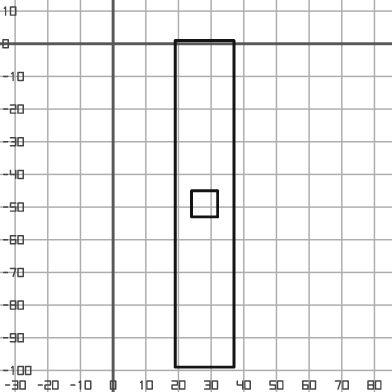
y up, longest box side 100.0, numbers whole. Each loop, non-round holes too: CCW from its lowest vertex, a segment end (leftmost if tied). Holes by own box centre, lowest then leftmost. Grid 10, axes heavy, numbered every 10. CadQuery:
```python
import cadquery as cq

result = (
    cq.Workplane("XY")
    .moveTo(19.0, -99.0)
    .lineTo(37.0, -99.0)
    .lineTo(37.0, 1.0)
    .lineTo(19.0, 1.0)
    .close()
    .moveTo(24.0, -53.0)
    .lineTo(32.0, -53.0)
    .lineTo(32.0, -45.0)
    .lineTo(24.0, -45.0)
    .close()
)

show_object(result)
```